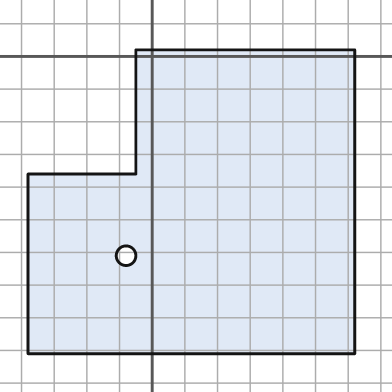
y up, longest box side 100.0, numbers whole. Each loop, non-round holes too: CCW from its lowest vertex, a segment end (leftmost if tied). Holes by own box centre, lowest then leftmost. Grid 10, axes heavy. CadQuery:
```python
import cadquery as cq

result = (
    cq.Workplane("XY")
    .moveTo(-38.0, -91.0)
    .lineTo(62.0, -91.0)
    .lineTo(62.0, 2.0)
    .lineTo(-5.0, 2.0)
    .lineTo(-5.0, -36.0)
    .lineTo(-38.0, -36.0)
    .close()
    .moveTo(-8.0, -61.0)
    .circle(3.0)
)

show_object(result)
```